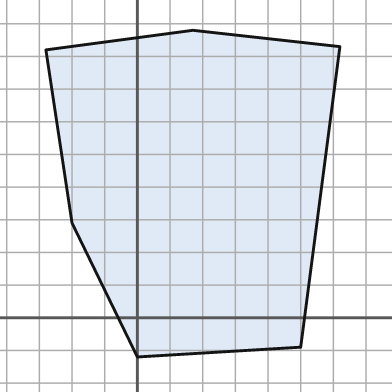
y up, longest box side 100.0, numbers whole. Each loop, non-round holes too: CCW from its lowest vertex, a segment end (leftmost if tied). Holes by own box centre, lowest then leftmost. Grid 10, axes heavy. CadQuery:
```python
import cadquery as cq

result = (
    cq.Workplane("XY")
    .moveTo(0.0, -12.0)
    .lineTo(50.0, -9.0)
    .lineTo(62.0, 83.0)
    .lineTo(17.0, 88.0)
    .lineTo(-28.0, 82.0)
    .lineTo(-20.0, 29.0)
    .close()
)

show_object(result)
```